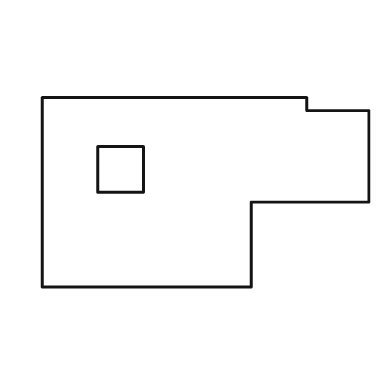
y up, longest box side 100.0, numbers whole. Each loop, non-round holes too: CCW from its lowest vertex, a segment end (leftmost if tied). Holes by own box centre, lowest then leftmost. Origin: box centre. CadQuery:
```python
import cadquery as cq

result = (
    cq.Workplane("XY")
    .moveTo(-50.0, -29.0)
    .lineTo(14.0, -29.0)
    .lineTo(14.0, -3.0)
    .lineTo(50.0, -3.0)
    .lineTo(50.0, 25.0)
    .lineTo(31.0, 25.0)
    .lineTo(31.0, 29.0)
    .lineTo(-50.0, 29.0)
    .close()
    .moveTo(-33.0, 0.0)
    .lineTo(-19.0, 0.0)
    .lineTo(-19.0, 14.0)
    .lineTo(-33.0, 14.0)
    .close()
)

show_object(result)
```